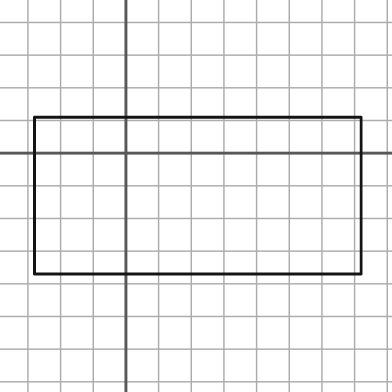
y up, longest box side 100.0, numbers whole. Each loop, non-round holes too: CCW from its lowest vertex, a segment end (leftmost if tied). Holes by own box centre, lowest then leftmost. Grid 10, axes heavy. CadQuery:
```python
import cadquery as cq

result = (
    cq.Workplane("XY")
    .moveTo(-28.0, -37.0)
    .lineTo(72.0, -37.0)
    .lineTo(72.0, 11.0)
    .lineTo(-28.0, 11.0)
    .close()
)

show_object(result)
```